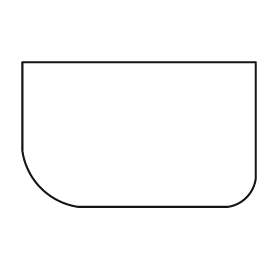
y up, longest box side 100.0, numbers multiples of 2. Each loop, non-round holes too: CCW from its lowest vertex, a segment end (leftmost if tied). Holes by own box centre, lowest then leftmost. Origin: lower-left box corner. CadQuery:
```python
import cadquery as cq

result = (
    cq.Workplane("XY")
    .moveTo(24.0, 0.0)
    .lineTo(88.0, 0.0)
    .threePointArc((96.0, 4.0), (100.0, 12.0))
    .lineTo(100.0, 62.0)
    .lineTo(0.0, 62.0)
    .lineTo(0.0, 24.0)
    .threePointArc((8.0, 8.0), (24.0, 0.0))
    .close()
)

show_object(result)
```